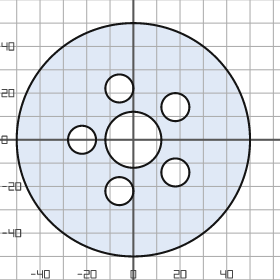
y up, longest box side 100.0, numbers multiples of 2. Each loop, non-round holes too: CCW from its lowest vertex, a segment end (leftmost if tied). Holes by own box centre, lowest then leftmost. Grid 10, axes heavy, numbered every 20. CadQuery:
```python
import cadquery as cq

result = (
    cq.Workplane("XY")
    .moveTo(0.0, 0.0)
    .circle(50.0)
    .moveTo(-6.0, -22.0)
    .circle(6.0)
    .moveTo(18.0, -14.0)
    .circle(6.0)
    .moveTo(-22.0, 0.0)
    .circle(6.0)
    .moveTo(0.0, 0.0)
    .circle(12.0)
    .moveTo(18.0, 14.0)
    .circle(6.0)
    .moveTo(-6.0, 22.0)
    .circle(6.0)
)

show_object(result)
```